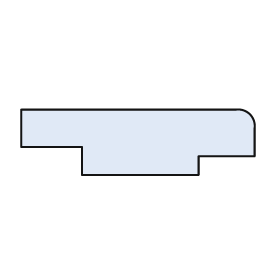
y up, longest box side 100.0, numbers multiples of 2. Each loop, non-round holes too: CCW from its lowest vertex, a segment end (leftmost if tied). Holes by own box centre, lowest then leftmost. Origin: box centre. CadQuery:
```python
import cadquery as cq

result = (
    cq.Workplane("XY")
    .moveTo(-24.0, -14.0)
    .lineTo(26.0, -14.0)
    .lineTo(26.0, -6.0)
    .lineTo(50.0, -6.0)
    .lineTo(50.0, 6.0)
    .threePointArc((48.0, 12.0), (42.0, 14.0))
    .lineTo(-50.0, 14.0)
    .lineTo(-50.0, -2.0)
    .lineTo(-24.0, -2.0)
    .close()
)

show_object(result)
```